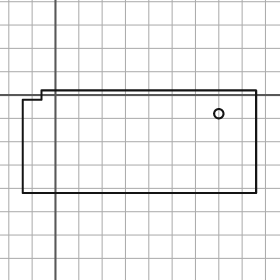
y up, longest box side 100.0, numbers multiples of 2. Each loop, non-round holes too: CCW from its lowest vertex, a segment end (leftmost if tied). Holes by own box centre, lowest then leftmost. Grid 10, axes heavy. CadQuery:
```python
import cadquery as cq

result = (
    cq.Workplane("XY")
    .moveTo(-14.0, -42.0)
    .lineTo(86.0, -42.0)
    .lineTo(86.0, 2.0)
    .lineTo(-6.0, 2.0)
    .lineTo(-6.0, -2.0)
    .lineTo(-14.0, -2.0)
    .close()
    .moveTo(70.0, -8.0)
    .circle(2.0)
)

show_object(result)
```